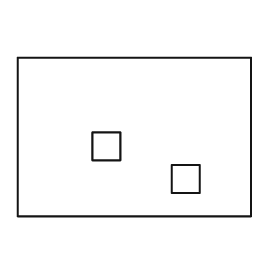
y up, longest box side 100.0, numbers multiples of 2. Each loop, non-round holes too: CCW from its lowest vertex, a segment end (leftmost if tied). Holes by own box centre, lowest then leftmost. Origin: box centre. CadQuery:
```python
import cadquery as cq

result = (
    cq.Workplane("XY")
    .moveTo(-50.0, -34.0)
    .lineTo(50.0, -34.0)
    .lineTo(50.0, 34.0)
    .lineTo(-50.0, 34.0)
    .close()
    .moveTo(16.0, -24.0)
    .lineTo(28.0, -24.0)
    .lineTo(28.0, -12.0)
    .lineTo(16.0, -12.0)
    .close()
    .moveTo(-18.0, -10.0)
    .lineTo(-6.0, -10.0)
    .lineTo(-6.0, 2.0)
    .lineTo(-18.0, 2.0)
    .close()
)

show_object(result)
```